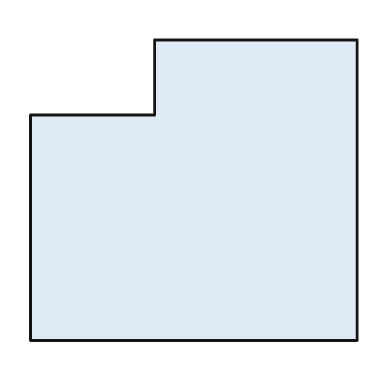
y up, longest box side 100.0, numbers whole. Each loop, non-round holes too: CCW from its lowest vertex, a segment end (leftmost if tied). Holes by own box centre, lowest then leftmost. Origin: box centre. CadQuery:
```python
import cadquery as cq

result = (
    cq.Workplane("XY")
    .moveTo(-50.0, -46.0)
    .lineTo(50.0, -46.0)
    .lineTo(50.0, 46.0)
    .lineTo(-12.0, 46.0)
    .lineTo(-12.0, 23.0)
    .lineTo(-50.0, 23.0)
    .close()
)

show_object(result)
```